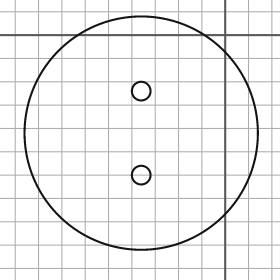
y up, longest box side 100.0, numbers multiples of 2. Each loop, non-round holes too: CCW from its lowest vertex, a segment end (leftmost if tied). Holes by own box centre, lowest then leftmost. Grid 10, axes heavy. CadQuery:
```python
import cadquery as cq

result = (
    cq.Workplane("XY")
    .moveTo(-36.0, -42.0)
    .circle(50.0)
    .moveTo(-36.0, -60.0)
    .circle(4.0)
    .moveTo(-36.0, -24.0)
    .circle(4.0)
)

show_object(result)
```